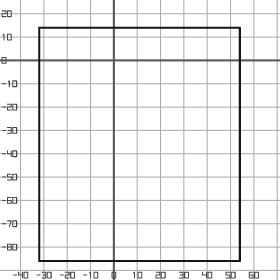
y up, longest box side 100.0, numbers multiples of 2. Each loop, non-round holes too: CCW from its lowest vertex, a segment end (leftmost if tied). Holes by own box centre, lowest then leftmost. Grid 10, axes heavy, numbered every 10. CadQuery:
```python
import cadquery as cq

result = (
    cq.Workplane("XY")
    .moveTo(-32.0, -86.0)
    .lineTo(54.0, -86.0)
    .lineTo(54.0, 14.0)
    .lineTo(-32.0, 14.0)
    .close()
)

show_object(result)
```